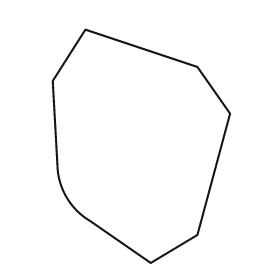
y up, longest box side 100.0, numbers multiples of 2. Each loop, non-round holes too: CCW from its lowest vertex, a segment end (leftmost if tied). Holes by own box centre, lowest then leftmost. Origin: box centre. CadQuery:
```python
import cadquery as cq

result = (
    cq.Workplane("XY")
    .moveTo(4.0, -50.0)
    .lineTo(24.0, -38.0)
    .lineTo(38.0, 14.0)
    .lineTo(24.0, 34.0)
    .lineTo(-24.0, 50.0)
    .lineTo(-38.0, 28.0)
    .lineTo(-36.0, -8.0)
    .threePointArc((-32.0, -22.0), (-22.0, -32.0))
    .close()
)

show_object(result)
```